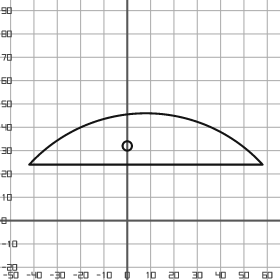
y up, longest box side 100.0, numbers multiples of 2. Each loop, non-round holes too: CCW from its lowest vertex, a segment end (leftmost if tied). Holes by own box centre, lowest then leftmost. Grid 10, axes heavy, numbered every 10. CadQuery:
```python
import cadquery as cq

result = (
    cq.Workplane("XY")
    .moveTo(-42.0, 24.0)
    .lineTo(58.0, 24.0)
    .threePointArc((8.0, 46.0), (-42.0, 24.0))
    .close()
    .moveTo(0.0, 32.0)
    .circle(2.0)
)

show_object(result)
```